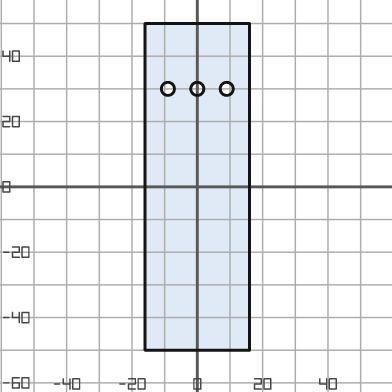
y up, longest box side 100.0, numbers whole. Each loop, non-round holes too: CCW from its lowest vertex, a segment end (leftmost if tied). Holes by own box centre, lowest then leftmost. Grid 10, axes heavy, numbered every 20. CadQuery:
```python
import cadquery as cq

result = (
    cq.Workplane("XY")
    .moveTo(-16.0, -50.0)
    .lineTo(16.0, -50.0)
    .lineTo(16.0, 50.0)
    .lineTo(-16.0, 50.0)
    .close()
    .moveTo(-9.0, 30.0)
    .circle(2.0)
    .moveTo(0.0, 30.0)
    .circle(2.0)
    .moveTo(9.0, 30.0)
    .circle(2.0)
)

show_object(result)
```